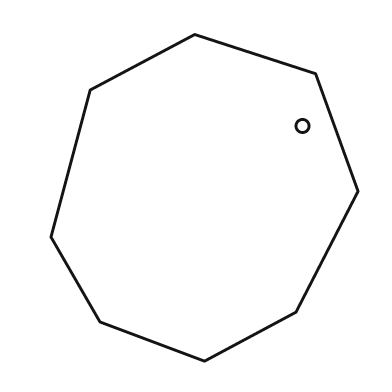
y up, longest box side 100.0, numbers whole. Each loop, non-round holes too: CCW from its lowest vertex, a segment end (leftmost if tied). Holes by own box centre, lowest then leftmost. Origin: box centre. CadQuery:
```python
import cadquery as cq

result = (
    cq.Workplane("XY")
    .moveTo(0.0, -50.0)
    .lineTo(28.0, -35.0)
    .lineTo(47.0, 2.0)
    .lineTo(34.0, 38.0)
    .lineTo(-3.0, 50.0)
    .lineTo(-35.0, 33.0)
    .lineTo(-47.0, -12.0)
    .lineTo(-32.0, -38.0)
    .close()
    .moveTo(30.0, 22.0)
    .circle(2.0)
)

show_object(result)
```